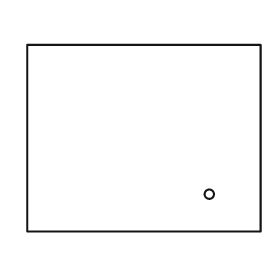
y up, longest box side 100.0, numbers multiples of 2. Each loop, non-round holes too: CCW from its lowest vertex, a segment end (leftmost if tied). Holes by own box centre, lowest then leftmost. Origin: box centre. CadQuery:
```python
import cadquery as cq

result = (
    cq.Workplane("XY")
    .moveTo(-50.0, -40.0)
    .lineTo(50.0, -40.0)
    .lineTo(50.0, 40.0)
    .lineTo(-50.0, 40.0)
    .close()
    .moveTo(28.0, -24.0)
    .circle(2.0)
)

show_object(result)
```